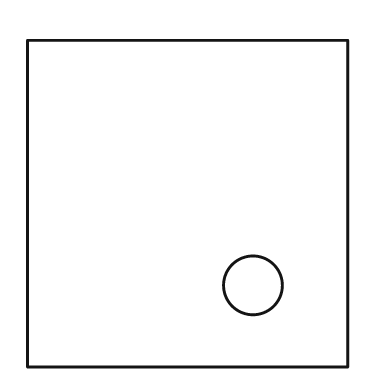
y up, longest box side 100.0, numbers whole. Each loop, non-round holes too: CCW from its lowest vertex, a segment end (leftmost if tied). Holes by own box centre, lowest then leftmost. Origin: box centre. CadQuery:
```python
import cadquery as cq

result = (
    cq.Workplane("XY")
    .moveTo(-49.0, -50.0)
    .lineTo(49.0, -50.0)
    .lineTo(49.0, 50.0)
    .lineTo(-49.0, 50.0)
    .close()
    .moveTo(20.0, -25.0)
    .circle(9.0)
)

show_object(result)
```